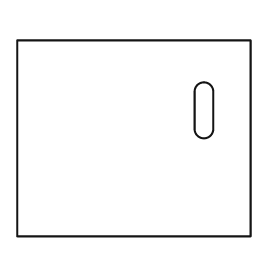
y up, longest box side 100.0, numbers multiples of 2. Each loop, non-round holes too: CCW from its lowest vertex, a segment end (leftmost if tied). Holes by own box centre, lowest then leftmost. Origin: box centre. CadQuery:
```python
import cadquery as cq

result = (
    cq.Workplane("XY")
    .moveTo(-50.0, -42.0)
    .lineTo(50.0, -42.0)
    .lineTo(50.0, 42.0)
    .lineTo(-50.0, 42.0)
    .close()
    .moveTo(26.0, 4.0)
    .threePointArc((30.0, 0.0), (34.0, 4.0))
    .lineTo(34.0, 20.0)
    .threePointArc((30.0, 24.0), (26.0, 20.0))
    .close()
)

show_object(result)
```